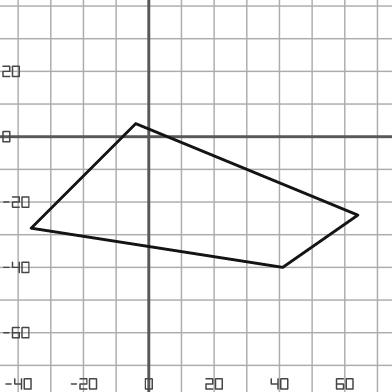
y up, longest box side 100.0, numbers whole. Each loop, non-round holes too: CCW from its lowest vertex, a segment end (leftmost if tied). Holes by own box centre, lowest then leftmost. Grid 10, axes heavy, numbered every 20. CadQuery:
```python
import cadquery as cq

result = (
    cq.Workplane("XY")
    .moveTo(41.0, -40.0)
    .lineTo(64.0, -24.0)
    .lineTo(-4.0, 4.0)
    .lineTo(-36.0, -28.0)
    .close()
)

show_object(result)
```